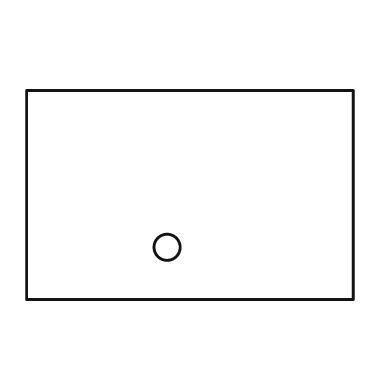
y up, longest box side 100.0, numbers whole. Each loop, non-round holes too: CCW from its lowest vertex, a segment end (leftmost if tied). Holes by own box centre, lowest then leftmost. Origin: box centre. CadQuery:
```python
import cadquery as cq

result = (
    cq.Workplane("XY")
    .moveTo(-50.0, -32.0)
    .lineTo(50.0, -32.0)
    .lineTo(50.0, 32.0)
    .lineTo(-50.0, 32.0)
    .close()
    .moveTo(-7.0, -16.0)
    .circle(4.0)
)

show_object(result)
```